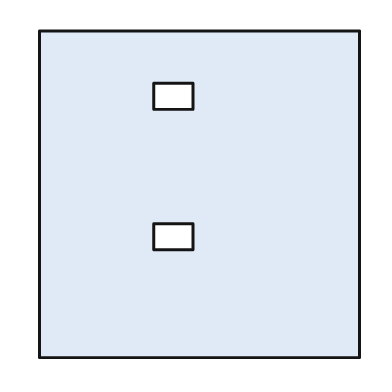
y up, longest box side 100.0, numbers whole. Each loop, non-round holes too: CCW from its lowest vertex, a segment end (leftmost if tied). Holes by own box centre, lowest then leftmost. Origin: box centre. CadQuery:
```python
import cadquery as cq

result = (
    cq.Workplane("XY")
    .moveTo(-49.0, -50.0)
    .lineTo(49.0, -50.0)
    .lineTo(49.0, 50.0)
    .lineTo(-49.0, 50.0)
    .close()
    .moveTo(-14.0, -17.0)
    .lineTo(-2.0, -17.0)
    .lineTo(-2.0, -9.0)
    .lineTo(-14.0, -9.0)
    .close()
    .moveTo(-14.0, 26.0)
    .lineTo(-2.0, 26.0)
    .lineTo(-2.0, 34.0)
    .lineTo(-14.0, 34.0)
    .close()
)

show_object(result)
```